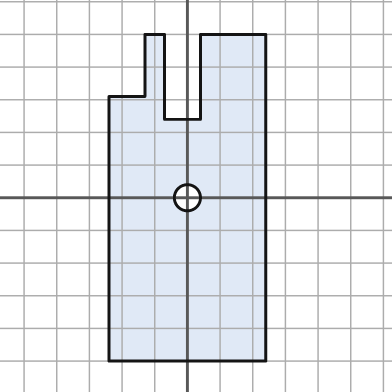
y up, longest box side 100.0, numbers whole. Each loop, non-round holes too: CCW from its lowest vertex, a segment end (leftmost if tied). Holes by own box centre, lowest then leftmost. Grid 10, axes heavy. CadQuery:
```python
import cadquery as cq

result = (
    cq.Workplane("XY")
    .moveTo(-24.0, -50.0)
    .lineTo(24.0, -50.0)
    .lineTo(24.0, 50.0)
    .lineTo(4.0, 50.0)
    .lineTo(4.0, 24.0)
    .lineTo(-7.0, 24.0)
    .lineTo(-7.0, 50.0)
    .lineTo(-13.0, 50.0)
    .lineTo(-13.0, 31.0)
    .lineTo(-24.0, 31.0)
    .close()
    .moveTo(0.0, 0.0)
    .circle(4.0)
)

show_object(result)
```